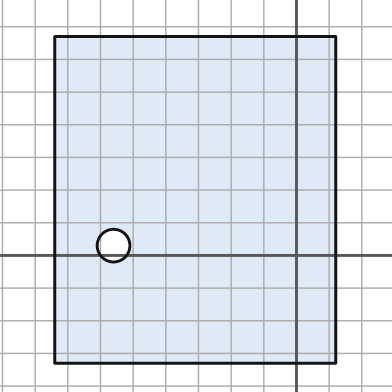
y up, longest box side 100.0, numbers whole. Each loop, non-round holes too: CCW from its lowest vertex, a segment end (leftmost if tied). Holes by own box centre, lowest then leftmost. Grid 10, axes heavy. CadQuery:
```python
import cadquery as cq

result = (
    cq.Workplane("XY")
    .moveTo(-74.0, -33.0)
    .lineTo(12.0, -33.0)
    .lineTo(12.0, 67.0)
    .lineTo(-74.0, 67.0)
    .close()
    .moveTo(-56.0, 3.0)
    .circle(5.0)
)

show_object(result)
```